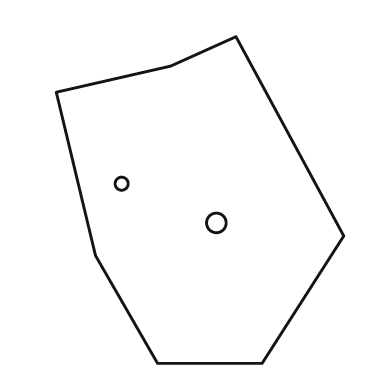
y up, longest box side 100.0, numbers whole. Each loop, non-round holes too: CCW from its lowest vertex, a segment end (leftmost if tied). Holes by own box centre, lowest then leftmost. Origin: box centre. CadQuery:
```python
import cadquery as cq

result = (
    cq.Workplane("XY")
    .moveTo(-13.0, -50.0)
    .lineTo(19.0, -50.0)
    .lineTo(44.0, -11.0)
    .lineTo(11.0, 50.0)
    .lineTo(-9.0, 41.0)
    .lineTo(-44.0, 33.0)
    .lineTo(-32.0, -17.0)
    .close()
    .moveTo(5.0, -7.0)
    .circle(3.0)
    .moveTo(-24.0, 5.0)
    .circle(2.0)
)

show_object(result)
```